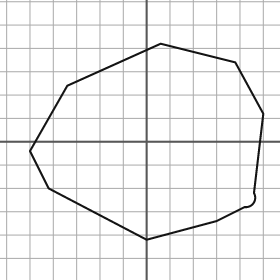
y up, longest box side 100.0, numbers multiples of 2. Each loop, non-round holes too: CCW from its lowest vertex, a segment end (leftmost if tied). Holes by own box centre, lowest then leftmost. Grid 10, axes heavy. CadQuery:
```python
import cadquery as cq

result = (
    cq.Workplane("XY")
    .moveTo(0.0, -42.0)
    .lineTo(30.0, -34.0)
    .lineTo(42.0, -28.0)
    .threePointArc((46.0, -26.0), (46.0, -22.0))
    .lineTo(50.0, 12.0)
    .lineTo(38.0, 34.0)
    .lineTo(6.0, 42.0)
    .lineTo(-34.0, 24.0)
    .lineTo(-50.0, -4.0)
    .lineTo(-42.0, -20.0)
    .close()
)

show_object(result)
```